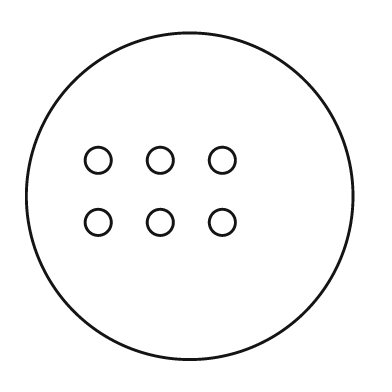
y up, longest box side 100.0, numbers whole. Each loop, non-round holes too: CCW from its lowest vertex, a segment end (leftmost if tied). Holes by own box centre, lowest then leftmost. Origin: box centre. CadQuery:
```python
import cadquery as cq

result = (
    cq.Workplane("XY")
    .moveTo(0.0, 0.0)
    .circle(50.0)
    .moveTo(-28.0, -8.0)
    .circle(4.0)
    .moveTo(-9.0, -8.0)
    .circle(4.0)
    .moveTo(10.0, -8.0)
    .circle(4.0)
    .moveTo(-28.0, 11.0)
    .circle(4.0)
    .moveTo(-9.0, 11.0)
    .circle(4.0)
    .moveTo(10.0, 11.0)
    .circle(4.0)
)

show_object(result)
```